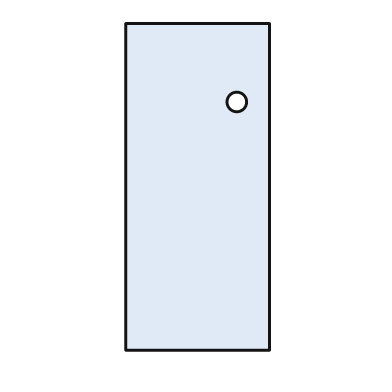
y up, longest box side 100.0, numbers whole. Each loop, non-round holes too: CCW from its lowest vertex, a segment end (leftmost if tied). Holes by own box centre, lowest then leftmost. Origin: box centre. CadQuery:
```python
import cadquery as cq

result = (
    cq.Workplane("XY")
    .moveTo(-22.0, -50.0)
    .lineTo(22.0, -50.0)
    .lineTo(22.0, 50.0)
    .lineTo(-22.0, 50.0)
    .close()
    .moveTo(12.0, 26.0)
    .circle(3.0)
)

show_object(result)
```